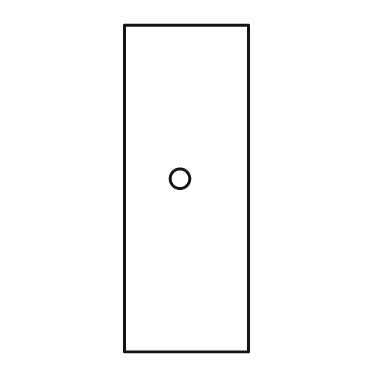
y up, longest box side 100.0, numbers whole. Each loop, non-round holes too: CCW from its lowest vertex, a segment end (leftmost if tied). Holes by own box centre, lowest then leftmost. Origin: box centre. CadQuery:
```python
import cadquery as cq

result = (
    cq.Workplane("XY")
    .moveTo(-19.0, -50.0)
    .lineTo(19.0, -50.0)
    .lineTo(19.0, 50.0)
    .lineTo(-19.0, 50.0)
    .close()
    .moveTo(-2.0, 3.0)
    .circle(3.0)
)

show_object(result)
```